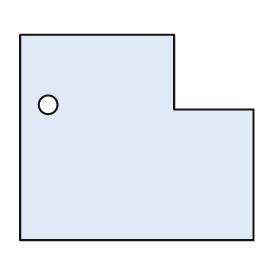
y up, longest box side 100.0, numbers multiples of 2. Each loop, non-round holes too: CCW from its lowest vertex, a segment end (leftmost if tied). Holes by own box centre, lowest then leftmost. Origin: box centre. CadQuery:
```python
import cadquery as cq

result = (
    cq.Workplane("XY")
    .moveTo(-50.0, -44.0)
    .lineTo(50.0, -44.0)
    .lineTo(50.0, 12.0)
    .lineTo(16.0, 12.0)
    .lineTo(16.0, 44.0)
    .lineTo(-50.0, 44.0)
    .close()
    .moveTo(-38.0, 14.0)
    .circle(4.0)
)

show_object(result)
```